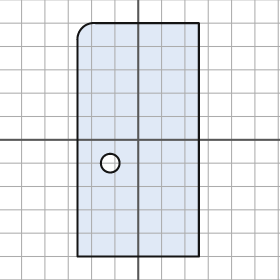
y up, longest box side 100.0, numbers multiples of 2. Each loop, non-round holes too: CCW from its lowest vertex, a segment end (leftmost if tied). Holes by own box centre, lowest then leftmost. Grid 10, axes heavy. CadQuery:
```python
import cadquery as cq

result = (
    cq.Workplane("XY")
    .moveTo(-26.0, -50.0)
    .lineTo(26.0, -50.0)
    .lineTo(26.0, 50.0)
    .lineTo(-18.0, 50.0)
    .threePointArc((-24.0, 48.0), (-26.0, 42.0))
    .close()
    .moveTo(-12.0, -10.0)
    .circle(4.0)
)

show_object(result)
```